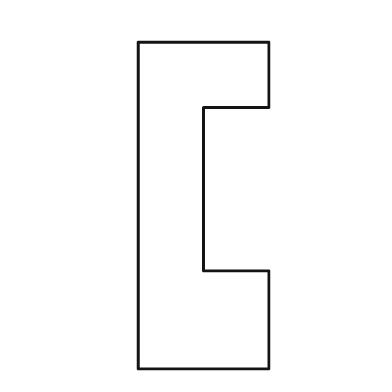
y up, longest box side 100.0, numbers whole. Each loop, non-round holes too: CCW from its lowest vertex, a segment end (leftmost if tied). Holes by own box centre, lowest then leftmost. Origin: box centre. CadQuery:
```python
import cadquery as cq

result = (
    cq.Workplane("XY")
    .moveTo(-20.0, -50.0)
    .lineTo(20.0, -50.0)
    .lineTo(20.0, -20.0)
    .lineTo(0.0, -20.0)
    .lineTo(0.0, 30.0)
    .lineTo(20.0, 30.0)
    .lineTo(20.0, 50.0)
    .lineTo(-20.0, 50.0)
    .close()
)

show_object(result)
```